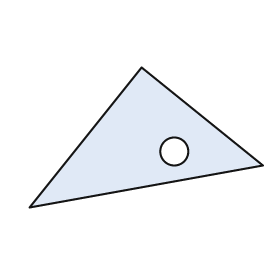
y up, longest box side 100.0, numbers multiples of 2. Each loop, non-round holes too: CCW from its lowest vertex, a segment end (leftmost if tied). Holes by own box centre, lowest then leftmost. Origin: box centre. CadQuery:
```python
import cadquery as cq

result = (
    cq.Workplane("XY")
    .moveTo(-50.0, -30.0)
    .lineTo(50.0, -12.0)
    .lineTo(-2.0, 30.0)
    .close()
    .moveTo(12.0, -6.0)
    .circle(6.0)
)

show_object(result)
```